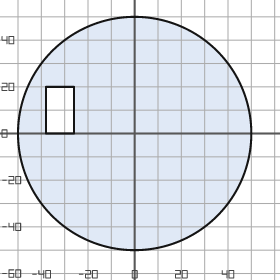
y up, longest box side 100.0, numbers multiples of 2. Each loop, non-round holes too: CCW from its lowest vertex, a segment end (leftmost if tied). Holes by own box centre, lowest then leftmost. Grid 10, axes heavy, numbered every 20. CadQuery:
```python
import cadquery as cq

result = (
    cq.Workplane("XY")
    .moveTo(0.0, 0.0)
    .circle(50.0)
    .moveTo(-38.0, 0.0)
    .lineTo(-26.0, 0.0)
    .lineTo(-26.0, 20.0)
    .lineTo(-38.0, 20.0)
    .close()
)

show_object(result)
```